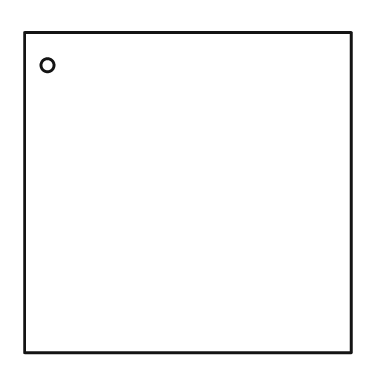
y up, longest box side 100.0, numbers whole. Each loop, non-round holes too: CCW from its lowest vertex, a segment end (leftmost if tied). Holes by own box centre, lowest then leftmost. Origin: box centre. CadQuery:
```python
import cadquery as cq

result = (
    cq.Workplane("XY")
    .moveTo(-50.0, -49.0)
    .lineTo(50.0, -49.0)
    .lineTo(50.0, 49.0)
    .lineTo(-50.0, 49.0)
    .close()
    .moveTo(-43.0, 39.0)
    .circle(2.0)
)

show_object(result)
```